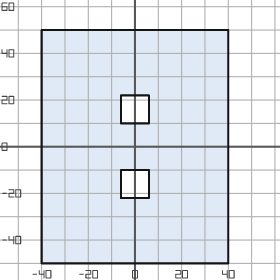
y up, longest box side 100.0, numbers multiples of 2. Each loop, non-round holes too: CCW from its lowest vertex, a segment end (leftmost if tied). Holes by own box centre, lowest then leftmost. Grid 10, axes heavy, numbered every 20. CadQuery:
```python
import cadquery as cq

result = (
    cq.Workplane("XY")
    .moveTo(-40.0, -50.0)
    .lineTo(40.0, -50.0)
    .lineTo(40.0, 50.0)
    .lineTo(-40.0, 50.0)
    .close()
    .moveTo(-6.0, -22.0)
    .lineTo(6.0, -22.0)
    .lineTo(6.0, -10.0)
    .lineTo(-6.0, -10.0)
    .close()
    .moveTo(-6.0, 10.0)
    .lineTo(6.0, 10.0)
    .lineTo(6.0, 22.0)
    .lineTo(-6.0, 22.0)
    .close()
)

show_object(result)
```